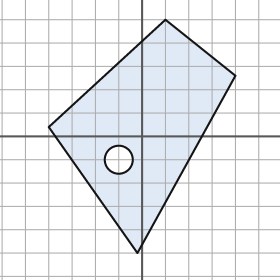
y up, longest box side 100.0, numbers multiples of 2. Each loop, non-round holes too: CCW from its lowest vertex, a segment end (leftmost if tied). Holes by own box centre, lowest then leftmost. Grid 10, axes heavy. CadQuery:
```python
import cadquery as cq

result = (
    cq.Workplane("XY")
    .moveTo(-2.0, -50.0)
    .lineTo(40.0, 26.0)
    .lineTo(10.0, 50.0)
    .lineTo(-40.0, 4.0)
    .close()
    .moveTo(-10.0, -10.0)
    .circle(6.0)
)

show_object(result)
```